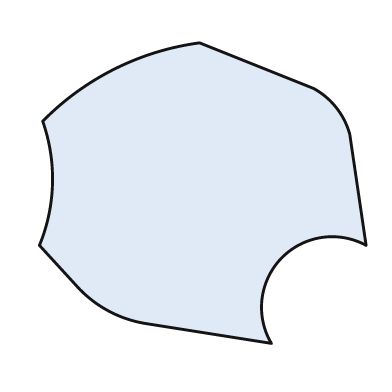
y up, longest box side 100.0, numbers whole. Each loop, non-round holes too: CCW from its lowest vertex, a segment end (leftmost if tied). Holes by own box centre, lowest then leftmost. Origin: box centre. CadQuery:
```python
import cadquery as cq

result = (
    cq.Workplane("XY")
    .moveTo(21.0, -46.0)
    .threePointArc((24.0, -20.0), (50.0, -16.0))
    .lineTo(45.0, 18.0)
    .threePointArc((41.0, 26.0), (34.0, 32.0))
    .lineTo(-1.0, 46.0)
    .threePointArc((-27.0, 38.0), (-49.0, 22.0))
    .threePointArc((-46.0, 3.0), (-50.0, -16.0))
    .lineTo(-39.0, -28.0)
    .threePointArc((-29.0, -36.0), (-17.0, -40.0))
    .close()
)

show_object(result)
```